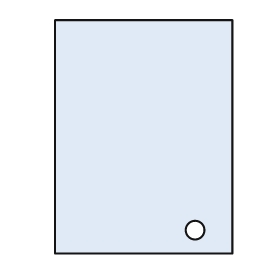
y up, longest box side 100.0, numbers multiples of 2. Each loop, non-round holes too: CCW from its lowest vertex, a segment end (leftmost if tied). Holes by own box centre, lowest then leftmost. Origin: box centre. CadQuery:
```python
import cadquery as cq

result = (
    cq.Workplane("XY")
    .moveTo(-38.0, -50.0)
    .lineTo(38.0, -50.0)
    .lineTo(38.0, 50.0)
    .lineTo(-38.0, 50.0)
    .close()
    .moveTo(22.0, -40.0)
    .circle(4.0)
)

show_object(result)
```